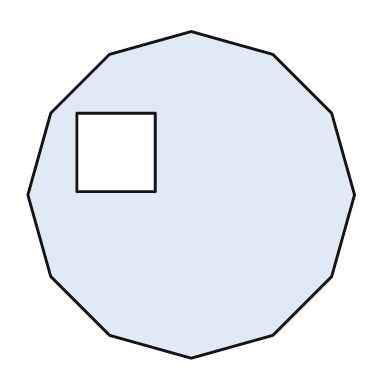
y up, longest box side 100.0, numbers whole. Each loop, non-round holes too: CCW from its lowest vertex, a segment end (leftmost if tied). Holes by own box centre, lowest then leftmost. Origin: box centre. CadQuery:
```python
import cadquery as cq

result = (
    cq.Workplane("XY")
    .moveTo(0.0, -50.0)
    .lineTo(25.0, -43.0)
    .lineTo(43.0, -25.0)
    .lineTo(50.0, 0.0)
    .lineTo(43.0, 25.0)
    .lineTo(25.0, 43.0)
    .lineTo(0.0, 50.0)
    .lineTo(-25.0, 43.0)
    .lineTo(-43.0, 25.0)
    .lineTo(-50.0, 0.0)
    .lineTo(-43.0, -25.0)
    .lineTo(-25.0, -43.0)
    .close()
    .moveTo(-35.0, 1.0)
    .lineTo(-11.0, 1.0)
    .lineTo(-11.0, 25.0)
    .lineTo(-35.0, 25.0)
    .close()
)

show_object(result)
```